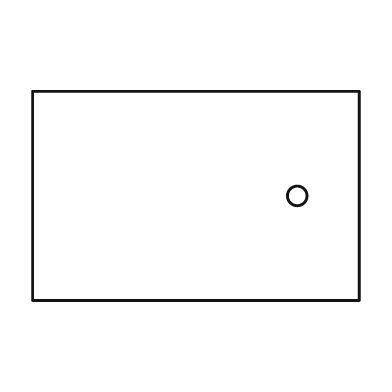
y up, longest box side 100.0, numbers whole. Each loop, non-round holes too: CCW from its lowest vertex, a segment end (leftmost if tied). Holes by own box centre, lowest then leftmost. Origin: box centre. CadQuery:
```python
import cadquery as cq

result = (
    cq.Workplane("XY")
    .moveTo(-50.0, -32.0)
    .lineTo(50.0, -32.0)
    .lineTo(50.0, 32.0)
    .lineTo(-50.0, 32.0)
    .close()
    .moveTo(31.0, 0.0)
    .circle(3.0)
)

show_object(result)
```